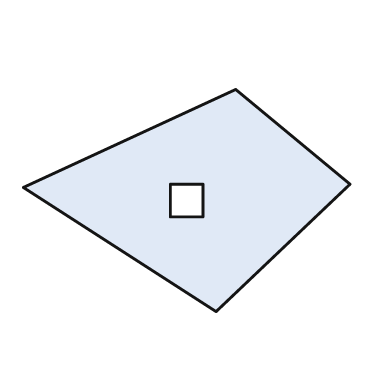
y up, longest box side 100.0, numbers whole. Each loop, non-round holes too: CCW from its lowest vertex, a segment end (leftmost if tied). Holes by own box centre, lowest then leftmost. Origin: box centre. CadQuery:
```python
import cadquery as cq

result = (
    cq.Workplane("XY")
    .moveTo(9.0, -34.0)
    .lineTo(50.0, 5.0)
    .lineTo(15.0, 34.0)
    .lineTo(-50.0, 4.0)
    .close()
    .moveTo(-5.0, -5.0)
    .lineTo(5.0, -5.0)
    .lineTo(5.0, 5.0)
    .lineTo(-5.0, 5.0)
    .close()
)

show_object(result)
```